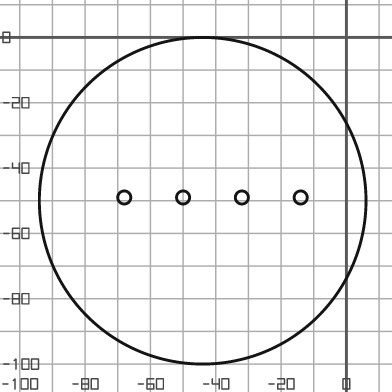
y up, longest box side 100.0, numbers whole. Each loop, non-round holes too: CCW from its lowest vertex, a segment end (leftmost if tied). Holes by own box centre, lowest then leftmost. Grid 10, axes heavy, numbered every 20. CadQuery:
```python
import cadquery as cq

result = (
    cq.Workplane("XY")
    .moveTo(-44.0, -50.0)
    .circle(50.0)
    .moveTo(-68.0, -49.0)
    .circle(2.0)
    .moveTo(-50.0, -49.0)
    .circle(2.0)
    .moveTo(-32.0, -49.0)
    .circle(2.0)
    .moveTo(-14.0, -49.0)
    .circle(2.0)
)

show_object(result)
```